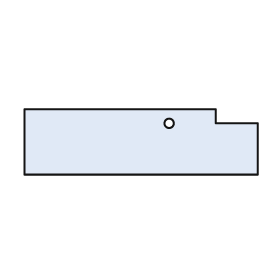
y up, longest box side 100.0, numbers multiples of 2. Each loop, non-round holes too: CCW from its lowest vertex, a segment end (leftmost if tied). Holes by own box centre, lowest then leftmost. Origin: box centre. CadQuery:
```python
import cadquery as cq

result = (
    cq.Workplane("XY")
    .moveTo(-50.0, -14.0)
    .lineTo(50.0, -14.0)
    .lineTo(50.0, 8.0)
    .lineTo(32.0, 8.0)
    .lineTo(32.0, 14.0)
    .lineTo(-50.0, 14.0)
    .close()
    .moveTo(12.0, 8.0)
    .circle(2.0)
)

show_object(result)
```